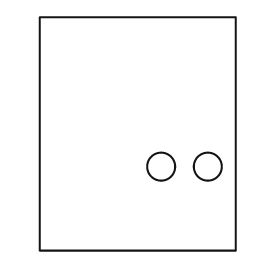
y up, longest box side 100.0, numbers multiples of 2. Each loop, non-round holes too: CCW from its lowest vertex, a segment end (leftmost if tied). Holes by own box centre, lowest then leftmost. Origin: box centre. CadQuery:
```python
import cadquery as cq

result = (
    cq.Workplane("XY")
    .moveTo(-42.0, -50.0)
    .lineTo(42.0, -50.0)
    .lineTo(42.0, 50.0)
    .lineTo(-42.0, 50.0)
    .close()
    .moveTo(10.0, -14.0)
    .circle(6.0)
    .moveTo(30.0, -14.0)
    .circle(6.0)
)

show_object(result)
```